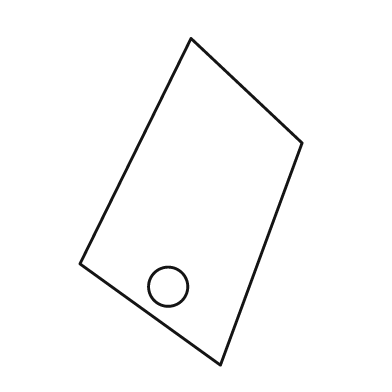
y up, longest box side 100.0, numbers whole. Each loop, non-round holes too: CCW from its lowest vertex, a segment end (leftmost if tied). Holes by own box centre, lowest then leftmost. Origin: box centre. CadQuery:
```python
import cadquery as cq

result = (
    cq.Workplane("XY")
    .moveTo(9.0, -50.0)
    .lineTo(34.0, 18.0)
    .lineTo(0.0, 50.0)
    .lineTo(-34.0, -19.0)
    .close()
    .moveTo(-7.0, -26.0)
    .circle(6.0)
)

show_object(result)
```